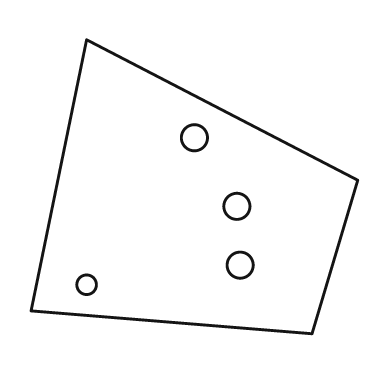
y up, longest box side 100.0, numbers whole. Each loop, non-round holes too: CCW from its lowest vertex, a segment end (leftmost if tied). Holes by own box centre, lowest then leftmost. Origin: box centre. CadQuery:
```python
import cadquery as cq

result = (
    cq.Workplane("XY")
    .moveTo(36.0, -45.0)
    .lineTo(50.0, 2.0)
    .lineTo(-33.0, 45.0)
    .lineTo(-50.0, -38.0)
    .close()
    .moveTo(-33.0, -30.0)
    .circle(3.0)
    .moveTo(14.0, -24.0)
    .circle(4.0)
    .moveTo(13.0, -6.0)
    .circle(4.0)
    .moveTo(0.0, 15.0)
    .circle(4.0)
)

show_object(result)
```